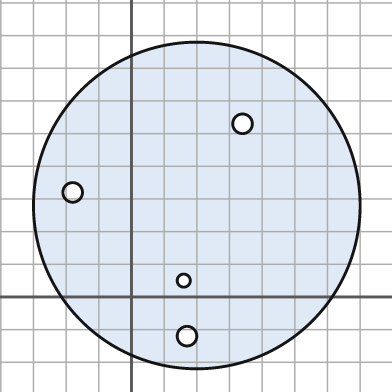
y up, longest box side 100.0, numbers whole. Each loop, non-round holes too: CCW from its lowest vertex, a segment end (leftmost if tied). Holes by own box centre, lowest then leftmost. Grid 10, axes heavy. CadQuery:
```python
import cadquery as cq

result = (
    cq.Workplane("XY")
    .moveTo(20.0, 28.0)
    .circle(50.0)
    .moveTo(17.0, -12.0)
    .circle(3.0)
    .moveTo(16.0, 5.0)
    .circle(2.0)
    .moveTo(-18.0, 32.0)
    .circle(3.0)
    .moveTo(34.0, 53.0)
    .circle(3.0)
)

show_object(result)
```